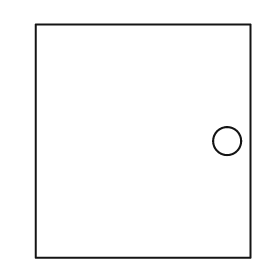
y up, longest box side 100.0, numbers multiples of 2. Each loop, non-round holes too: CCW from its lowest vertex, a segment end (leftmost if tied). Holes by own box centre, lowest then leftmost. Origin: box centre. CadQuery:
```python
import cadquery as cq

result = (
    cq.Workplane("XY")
    .moveTo(-46.0, -50.0)
    .lineTo(46.0, -50.0)
    .lineTo(46.0, 50.0)
    .lineTo(-46.0, 50.0)
    .close()
    .moveTo(36.0, 0.0)
    .circle(6.0)
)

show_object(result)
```